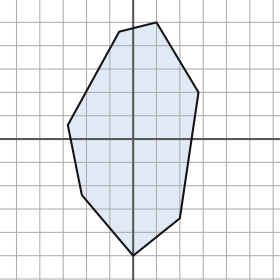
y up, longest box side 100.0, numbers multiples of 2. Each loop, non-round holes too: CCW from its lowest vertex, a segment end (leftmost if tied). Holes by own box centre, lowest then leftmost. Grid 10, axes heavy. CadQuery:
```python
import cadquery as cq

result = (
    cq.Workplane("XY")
    .moveTo(0.0, -50.0)
    .lineTo(20.0, -34.0)
    .lineTo(28.0, 20.0)
    .lineTo(10.0, 50.0)
    .lineTo(-6.0, 46.0)
    .lineTo(-28.0, 6.0)
    .lineTo(-22.0, -24.0)
    .close()
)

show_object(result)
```